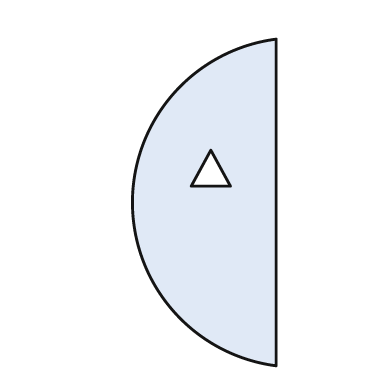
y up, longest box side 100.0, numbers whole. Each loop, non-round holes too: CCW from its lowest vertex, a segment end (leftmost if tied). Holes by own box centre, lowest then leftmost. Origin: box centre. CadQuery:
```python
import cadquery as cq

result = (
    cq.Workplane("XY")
    .moveTo(22.0, -50.0)
    .lineTo(22.0, 50.0)
    .threePointArc((-22.0, 0.0), (22.0, -50.0))
    .close()
    .moveTo(-4.0, 5.0)
    .lineTo(8.0, 5.0)
    .lineTo(2.0, 16.0)
    .close()
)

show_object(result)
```